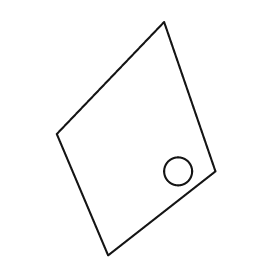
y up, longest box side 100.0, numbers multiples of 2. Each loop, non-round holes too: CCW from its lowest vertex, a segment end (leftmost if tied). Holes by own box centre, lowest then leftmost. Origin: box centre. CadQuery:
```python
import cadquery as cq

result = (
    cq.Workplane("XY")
    .moveTo(-12.0, -50.0)
    .lineTo(34.0, -14.0)
    .lineTo(12.0, 50.0)
    .lineTo(-34.0, 2.0)
    .close()
    .moveTo(18.0, -14.0)
    .circle(6.0)
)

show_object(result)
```